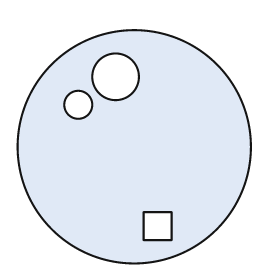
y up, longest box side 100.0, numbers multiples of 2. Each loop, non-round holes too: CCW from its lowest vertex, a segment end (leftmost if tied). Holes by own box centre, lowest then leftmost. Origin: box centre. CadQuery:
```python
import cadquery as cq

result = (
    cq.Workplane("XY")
    .moveTo(0.0, 0.0)
    .circle(50.0)
    .moveTo(4.0, -40.0)
    .lineTo(16.0, -40.0)
    .lineTo(16.0, -28.0)
    .lineTo(4.0, -28.0)
    .close()
    .moveTo(-24.0, 18.0)
    .circle(6.0)
    .moveTo(-8.0, 30.0)
    .circle(10.0)
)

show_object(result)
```